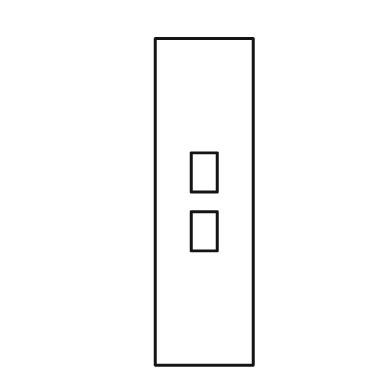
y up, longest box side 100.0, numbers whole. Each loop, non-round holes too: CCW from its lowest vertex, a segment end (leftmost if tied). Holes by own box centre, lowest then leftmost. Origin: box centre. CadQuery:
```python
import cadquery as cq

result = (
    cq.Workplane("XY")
    .moveTo(-15.0, -50.0)
    .lineTo(15.0, -50.0)
    .lineTo(15.0, 50.0)
    .lineTo(-15.0, 50.0)
    .close()
    .moveTo(-4.0, -15.0)
    .lineTo(4.0, -15.0)
    .lineTo(4.0, -3.0)
    .lineTo(-4.0, -3.0)
    .close()
    .moveTo(-4.0, 3.0)
    .lineTo(4.0, 3.0)
    .lineTo(4.0, 15.0)
    .lineTo(-4.0, 15.0)
    .close()
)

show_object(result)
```